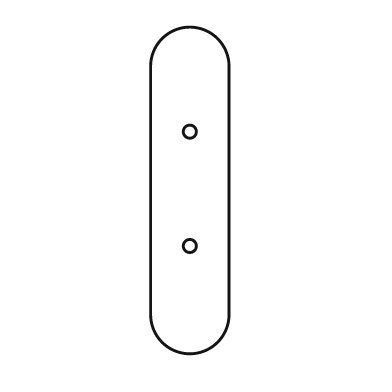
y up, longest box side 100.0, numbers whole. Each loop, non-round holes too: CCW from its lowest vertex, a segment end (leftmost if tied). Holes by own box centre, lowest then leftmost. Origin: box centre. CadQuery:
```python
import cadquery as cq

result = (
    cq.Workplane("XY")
    .moveTo(-12.0, -38.0)
    .threePointArc((0.0, -50.0), (12.0, -38.0))
    .lineTo(12.0, 38.0)
    .threePointArc((0.0, 50.0), (-12.0, 38.0))
    .close()
    .moveTo(0.0, -17.0)
    .circle(2.0)
    .moveTo(0.0, 18.0)
    .circle(2.0)
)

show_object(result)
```